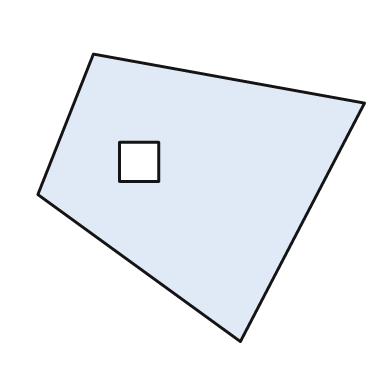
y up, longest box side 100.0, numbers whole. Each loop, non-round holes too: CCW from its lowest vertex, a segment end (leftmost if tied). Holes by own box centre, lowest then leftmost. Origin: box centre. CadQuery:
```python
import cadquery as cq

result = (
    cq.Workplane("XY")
    .moveTo(12.0, -44.0)
    .lineTo(50.0, 29.0)
    .lineTo(-33.0, 44.0)
    .lineTo(-50.0, 1.0)
    .close()
    .moveTo(-25.0, 5.0)
    .lineTo(-13.0, 5.0)
    .lineTo(-13.0, 17.0)
    .lineTo(-25.0, 17.0)
    .close()
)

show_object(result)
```